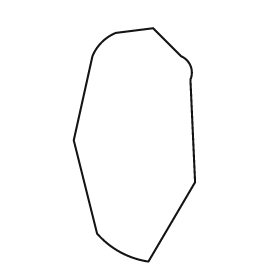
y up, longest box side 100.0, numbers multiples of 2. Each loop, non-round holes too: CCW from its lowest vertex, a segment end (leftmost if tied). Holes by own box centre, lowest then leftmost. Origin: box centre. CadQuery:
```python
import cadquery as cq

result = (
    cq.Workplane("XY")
    .moveTo(6.0, -50.0)
    .lineTo(26.0, -16.0)
    .lineTo(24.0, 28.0)
    .threePointArc((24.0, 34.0), (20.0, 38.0))
    .lineTo(8.0, 50.0)
    .lineTo(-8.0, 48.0)
    .threePointArc((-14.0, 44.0), (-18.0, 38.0))
    .lineTo(-26.0, 2.0)
    .lineTo(-16.0, -38.0)
    .threePointArc((-6.0, -46.0), (6.0, -50.0))
    .close()
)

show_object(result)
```